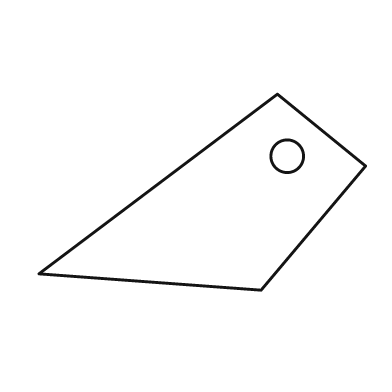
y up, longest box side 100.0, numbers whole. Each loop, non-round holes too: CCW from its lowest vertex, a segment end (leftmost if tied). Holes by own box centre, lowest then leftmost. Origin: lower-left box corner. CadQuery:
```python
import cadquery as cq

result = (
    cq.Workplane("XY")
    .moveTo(68.0, 0.0)
    .lineTo(100.0, 38.0)
    .lineTo(73.0, 60.0)
    .lineTo(0.0, 5.0)
    .close()
    .moveTo(76.0, 41.0)
    .circle(5.0)
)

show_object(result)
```